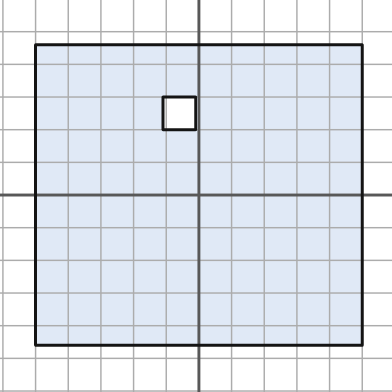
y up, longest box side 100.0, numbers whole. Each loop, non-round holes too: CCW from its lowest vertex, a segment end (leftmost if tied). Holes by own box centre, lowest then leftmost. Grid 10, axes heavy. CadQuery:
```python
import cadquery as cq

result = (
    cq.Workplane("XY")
    .moveTo(-50.0, -46.0)
    .lineTo(50.0, -46.0)
    .lineTo(50.0, 46.0)
    .lineTo(-50.0, 46.0)
    .close()
    .moveTo(-11.0, 20.0)
    .lineTo(-1.0, 20.0)
    .lineTo(-1.0, 30.0)
    .lineTo(-11.0, 30.0)
    .close()
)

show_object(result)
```